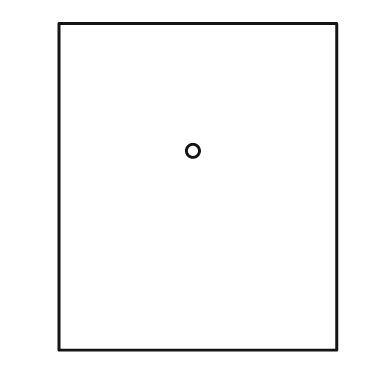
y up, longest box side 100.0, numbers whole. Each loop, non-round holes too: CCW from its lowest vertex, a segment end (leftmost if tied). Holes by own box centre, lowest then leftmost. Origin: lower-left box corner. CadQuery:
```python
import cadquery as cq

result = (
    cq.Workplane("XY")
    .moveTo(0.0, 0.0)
    .lineTo(85.0, 0.0)
    .lineTo(85.0, 100.0)
    .lineTo(0.0, 100.0)
    .close()
    .moveTo(41.0, 61.0)
    .circle(2.0)
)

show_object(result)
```